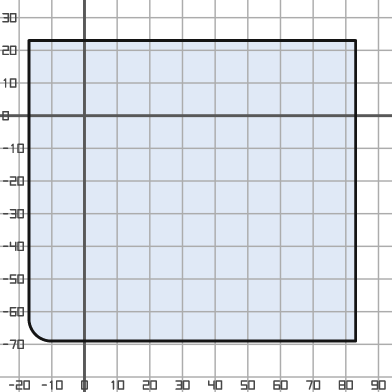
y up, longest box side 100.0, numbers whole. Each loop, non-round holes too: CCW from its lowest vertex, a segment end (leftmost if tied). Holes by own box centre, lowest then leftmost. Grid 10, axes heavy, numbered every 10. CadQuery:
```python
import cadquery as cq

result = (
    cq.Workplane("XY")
    .moveTo(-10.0, -69.0)
    .lineTo(83.0, -69.0)
    .lineTo(83.0, 23.0)
    .lineTo(-17.0, 23.0)
    .lineTo(-17.0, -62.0)
    .threePointArc((-15.0, -67.0), (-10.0, -69.0))
    .close()
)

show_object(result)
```